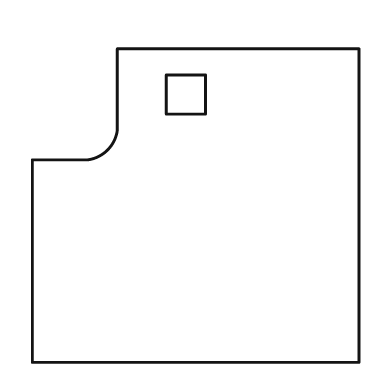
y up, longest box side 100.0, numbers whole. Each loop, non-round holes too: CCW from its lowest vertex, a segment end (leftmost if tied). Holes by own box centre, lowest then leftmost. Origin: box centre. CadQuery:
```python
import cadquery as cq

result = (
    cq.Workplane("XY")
    .moveTo(-50.0, -48.0)
    .lineTo(50.0, -48.0)
    .lineTo(50.0, 48.0)
    .lineTo(-24.0, 48.0)
    .lineTo(-24.0, 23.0)
    .threePointArc((-27.0, 17.0), (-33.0, 14.0))
    .lineTo(-50.0, 14.0)
    .close()
    .moveTo(-9.0, 28.0)
    .lineTo(3.0, 28.0)
    .lineTo(3.0, 40.0)
    .lineTo(-9.0, 40.0)
    .close()
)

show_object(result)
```